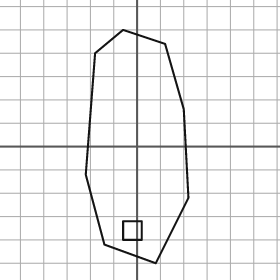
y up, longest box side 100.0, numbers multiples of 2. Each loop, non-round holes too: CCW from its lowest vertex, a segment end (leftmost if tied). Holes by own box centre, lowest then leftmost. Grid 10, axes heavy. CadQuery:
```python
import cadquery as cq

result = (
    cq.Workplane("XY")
    .moveTo(8.0, -50.0)
    .lineTo(22.0, -22.0)
    .lineTo(20.0, 16.0)
    .lineTo(12.0, 44.0)
    .lineTo(-6.0, 50.0)
    .lineTo(-18.0, 40.0)
    .lineTo(-22.0, -12.0)
    .lineTo(-14.0, -42.0)
    .close()
    .moveTo(-6.0, -40.0)
    .lineTo(2.0, -40.0)
    .lineTo(2.0, -32.0)
    .lineTo(-6.0, -32.0)
    .close()
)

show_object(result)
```